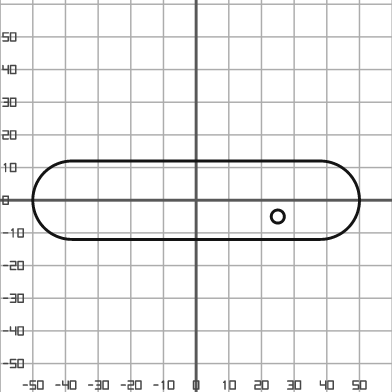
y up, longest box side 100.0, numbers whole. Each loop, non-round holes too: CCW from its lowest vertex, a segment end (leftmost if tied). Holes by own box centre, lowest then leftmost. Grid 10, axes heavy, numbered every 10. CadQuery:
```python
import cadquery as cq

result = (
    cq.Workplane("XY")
    .moveTo(-38.0, -12.0)
    .lineTo(38.0, -12.0)
    .threePointArc((50.0, 0.0), (38.0, 12.0))
    .lineTo(-38.0, 12.0)
    .threePointArc((-50.0, 0.0), (-38.0, -12.0))
    .close()
    .moveTo(25.0, -5.0)
    .circle(2.0)
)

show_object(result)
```